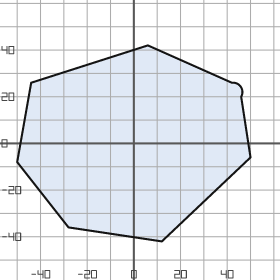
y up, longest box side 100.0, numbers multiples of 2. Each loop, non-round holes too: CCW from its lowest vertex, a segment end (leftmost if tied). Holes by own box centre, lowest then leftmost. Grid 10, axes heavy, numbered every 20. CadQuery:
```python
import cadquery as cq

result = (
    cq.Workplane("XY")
    .moveTo(12.0, -42.0)
    .lineTo(50.0, -6.0)
    .lineTo(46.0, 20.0)
    .threePointArc((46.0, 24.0), (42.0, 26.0))
    .lineTo(6.0, 42.0)
    .lineTo(-44.0, 26.0)
    .lineTo(-50.0, -8.0)
    .lineTo(-28.0, -36.0)
    .close()
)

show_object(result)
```